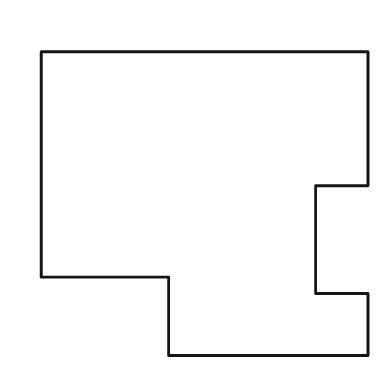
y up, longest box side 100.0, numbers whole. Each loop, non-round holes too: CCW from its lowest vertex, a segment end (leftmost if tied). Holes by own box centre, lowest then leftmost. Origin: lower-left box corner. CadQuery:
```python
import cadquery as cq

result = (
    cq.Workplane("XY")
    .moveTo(39.0, 0.0)
    .lineTo(100.0, 0.0)
    .lineTo(100.0, 19.0)
    .lineTo(84.0, 19.0)
    .lineTo(84.0, 52.0)
    .lineTo(100.0, 52.0)
    .lineTo(100.0, 93.0)
    .lineTo(0.0, 93.0)
    .lineTo(0.0, 24.0)
    .lineTo(39.0, 24.0)
    .close()
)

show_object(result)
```